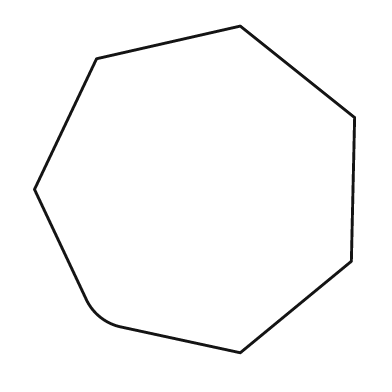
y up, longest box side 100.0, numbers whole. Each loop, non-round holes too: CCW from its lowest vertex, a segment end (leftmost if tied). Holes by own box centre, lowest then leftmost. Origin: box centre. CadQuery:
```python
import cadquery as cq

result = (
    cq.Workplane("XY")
    .moveTo(14.0, -50.0)
    .lineTo(48.0, -22.0)
    .lineTo(49.0, 22.0)
    .lineTo(14.0, 50.0)
    .lineTo(-30.0, 40.0)
    .lineTo(-49.0, 0.0)
    .lineTo(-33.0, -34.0)
    .threePointArc((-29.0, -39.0), (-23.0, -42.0))
    .close()
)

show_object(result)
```